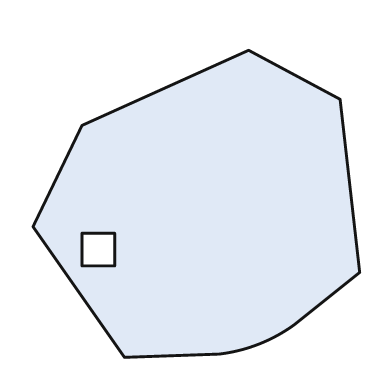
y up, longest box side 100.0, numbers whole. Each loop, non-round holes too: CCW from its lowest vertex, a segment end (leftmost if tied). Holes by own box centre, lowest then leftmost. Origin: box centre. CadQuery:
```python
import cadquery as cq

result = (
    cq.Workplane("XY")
    .moveTo(-22.0, -47.0)
    .lineTo(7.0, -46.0)
    .threePointArc((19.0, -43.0), (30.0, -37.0))
    .lineTo(50.0, -21.0)
    .lineTo(44.0, 32.0)
    .lineTo(16.0, 47.0)
    .lineTo(-35.0, 24.0)
    .lineTo(-50.0, -7.0)
    .close()
    .moveTo(-35.0, -19.0)
    .lineTo(-25.0, -19.0)
    .lineTo(-25.0, -9.0)
    .lineTo(-35.0, -9.0)
    .close()
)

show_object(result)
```